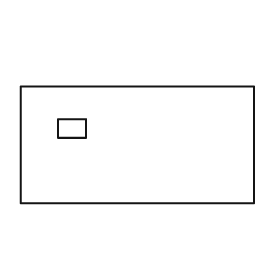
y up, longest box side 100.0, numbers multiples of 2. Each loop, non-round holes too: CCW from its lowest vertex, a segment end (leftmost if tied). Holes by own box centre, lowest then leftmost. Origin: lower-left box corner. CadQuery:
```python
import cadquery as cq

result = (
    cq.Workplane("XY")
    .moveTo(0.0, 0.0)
    .lineTo(100.0, 0.0)
    .lineTo(100.0, 50.0)
    .lineTo(0.0, 50.0)
    .close()
    .moveTo(16.0, 28.0)
    .lineTo(28.0, 28.0)
    .lineTo(28.0, 36.0)
    .lineTo(16.0, 36.0)
    .close()
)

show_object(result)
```